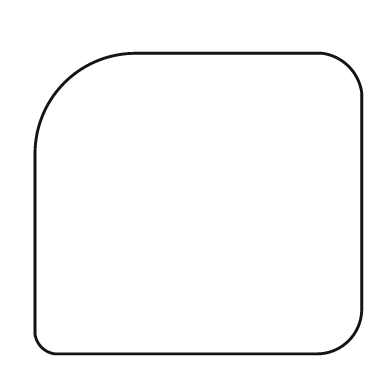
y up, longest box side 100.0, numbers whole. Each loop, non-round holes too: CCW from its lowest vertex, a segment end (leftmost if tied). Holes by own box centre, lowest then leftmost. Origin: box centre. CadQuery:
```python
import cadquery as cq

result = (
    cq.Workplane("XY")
    .moveTo(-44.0, -46.0)
    .lineTo(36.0, -46.0)
    .threePointArc((46.0, -42.0), (50.0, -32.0))
    .lineTo(50.0, 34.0)
    .threePointArc((46.0, 42.0), (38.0, 46.0))
    .lineTo(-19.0, 46.0)
    .threePointArc((-41.0, 37.0), (-50.0, 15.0))
    .lineTo(-50.0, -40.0)
    .threePointArc((-48.0, -44.0), (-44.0, -46.0))
    .close()
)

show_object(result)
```